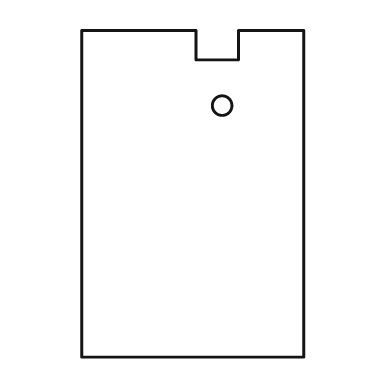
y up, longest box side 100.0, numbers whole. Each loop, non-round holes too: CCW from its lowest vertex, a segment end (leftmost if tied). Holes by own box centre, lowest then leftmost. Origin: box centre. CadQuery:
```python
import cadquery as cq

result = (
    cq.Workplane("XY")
    .moveTo(-34.0, -50.0)
    .lineTo(34.0, -50.0)
    .lineTo(34.0, 50.0)
    .lineTo(14.0, 50.0)
    .lineTo(14.0, 41.0)
    .lineTo(1.0, 41.0)
    .lineTo(1.0, 50.0)
    .lineTo(-34.0, 50.0)
    .close()
    .moveTo(9.0, 27.0)
    .circle(3.0)
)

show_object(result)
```